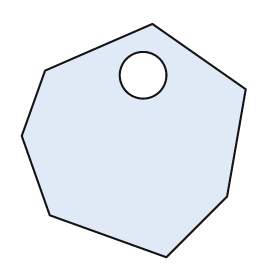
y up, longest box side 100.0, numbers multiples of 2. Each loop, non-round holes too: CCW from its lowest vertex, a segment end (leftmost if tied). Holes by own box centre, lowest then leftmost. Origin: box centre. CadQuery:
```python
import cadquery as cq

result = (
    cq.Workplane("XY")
    .moveTo(14.0, -50.0)
    .lineTo(40.0, -24.0)
    .lineTo(48.0, 22.0)
    .lineTo(8.0, 50.0)
    .lineTo(-38.0, 30.0)
    .lineTo(-48.0, 2.0)
    .lineTo(-36.0, -32.0)
    .close()
    .moveTo(4.0, 28.0)
    .circle(10.0)
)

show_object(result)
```